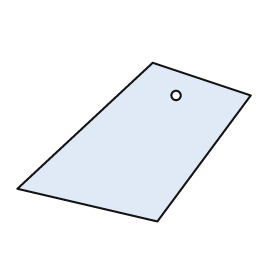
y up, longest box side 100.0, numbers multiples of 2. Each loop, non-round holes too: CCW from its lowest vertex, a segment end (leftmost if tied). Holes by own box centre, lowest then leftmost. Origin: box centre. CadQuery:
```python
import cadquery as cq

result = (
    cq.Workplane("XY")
    .moveTo(10.0, -34.0)
    .lineTo(50.0, 20.0)
    .lineTo(8.0, 34.0)
    .lineTo(-50.0, -20.0)
    .close()
    .moveTo(18.0, 20.0)
    .circle(2.0)
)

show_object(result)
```